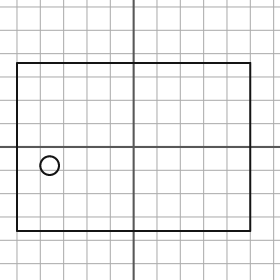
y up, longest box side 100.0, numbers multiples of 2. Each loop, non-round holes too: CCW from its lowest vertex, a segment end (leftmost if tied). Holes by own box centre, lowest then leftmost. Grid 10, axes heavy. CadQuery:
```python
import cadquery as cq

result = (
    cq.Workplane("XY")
    .moveTo(-50.0, -36.0)
    .lineTo(50.0, -36.0)
    .lineTo(50.0, 36.0)
    .lineTo(-50.0, 36.0)
    .close()
    .moveTo(-36.0, -8.0)
    .circle(4.0)
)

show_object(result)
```